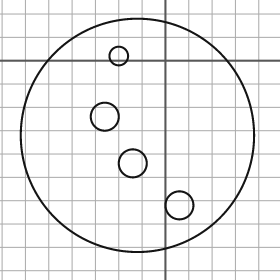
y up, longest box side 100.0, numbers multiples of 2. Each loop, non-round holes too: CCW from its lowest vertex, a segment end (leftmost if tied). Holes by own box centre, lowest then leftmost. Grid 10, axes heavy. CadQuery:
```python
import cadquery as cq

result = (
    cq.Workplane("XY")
    .moveTo(-12.0, -32.0)
    .circle(50.0)
    .moveTo(6.0, -62.0)
    .circle(6.0)
    .moveTo(-14.0, -44.0)
    .circle(6.0)
    .moveTo(-26.0, -24.0)
    .circle(6.0)
    .moveTo(-20.0, 2.0)
    .circle(4.0)
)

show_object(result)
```